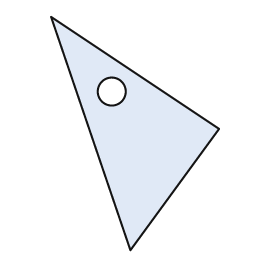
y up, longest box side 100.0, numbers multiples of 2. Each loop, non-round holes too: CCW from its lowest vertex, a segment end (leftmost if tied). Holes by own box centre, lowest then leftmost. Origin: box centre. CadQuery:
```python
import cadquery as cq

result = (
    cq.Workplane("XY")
    .moveTo(-2.0, -50.0)
    .lineTo(36.0, 2.0)
    .lineTo(-36.0, 50.0)
    .close()
    .moveTo(-10.0, 18.0)
    .circle(6.0)
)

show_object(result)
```